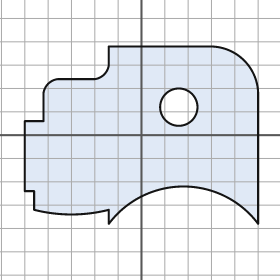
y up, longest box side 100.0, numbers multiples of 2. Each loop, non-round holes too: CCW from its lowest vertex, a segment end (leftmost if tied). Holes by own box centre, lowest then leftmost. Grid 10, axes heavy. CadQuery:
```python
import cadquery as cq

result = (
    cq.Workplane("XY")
    .moveTo(-14.0, -38.0)
    .threePointArc((18.0, -22.0), (50.0, -38.0))
    .lineTo(50.0, 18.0)
    .threePointArc((44.0, 32.0), (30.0, 38.0))
    .lineTo(-14.0, 38.0)
    .lineTo(-14.0, 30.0)
    .threePointArc((-16.0, 26.0), (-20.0, 24.0))
    .lineTo(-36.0, 24.0)
    .threePointArc((-40.0, 22.0), (-42.0, 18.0))
    .lineTo(-42.0, 6.0)
    .lineTo(-50.0, 6.0)
    .lineTo(-50.0, -24.0)
    .lineTo(-46.0, -24.0)
    .lineTo(-46.0, -32.0)
    .threePointArc((-30.0, -34.0), (-14.0, -32.0))
    .close()
    .moveTo(16.0, 12.0)
    .circle(8.0)
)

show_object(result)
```